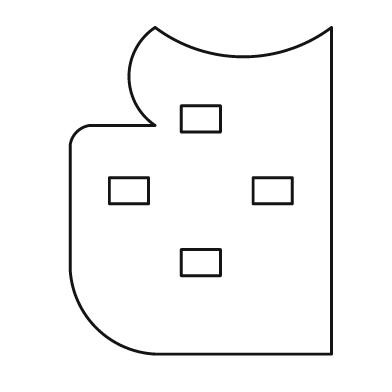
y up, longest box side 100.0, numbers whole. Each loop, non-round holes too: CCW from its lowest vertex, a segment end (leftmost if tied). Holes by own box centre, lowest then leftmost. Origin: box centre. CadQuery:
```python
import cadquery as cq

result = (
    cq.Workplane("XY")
    .moveTo(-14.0, -50.0)
    .lineTo(40.0, -50.0)
    .lineTo(40.0, 50.0)
    .threePointArc((13.0, 41.0), (-14.0, 50.0))
    .threePointArc((-22.0, 35.0), (-14.0, 20.0))
    .lineTo(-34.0, 20.0)
    .threePointArc((-38.0, 18.0), (-40.0, 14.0))
    .lineTo(-40.0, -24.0)
    .threePointArc((-32.0, -42.0), (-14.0, -50.0))
    .close()
    .moveTo(-6.0, -26.0)
    .lineTo(6.0, -26.0)
    .lineTo(6.0, -18.0)
    .lineTo(-6.0, -18.0)
    .close()
    .moveTo(-28.0, -4.0)
    .lineTo(-16.0, -4.0)
    .lineTo(-16.0, 4.0)
    .lineTo(-28.0, 4.0)
    .close()
    .moveTo(16.0, -4.0)
    .lineTo(28.0, -4.0)
    .lineTo(28.0, 4.0)
    .lineTo(16.0, 4.0)
    .close()
    .moveTo(-6.0, 18.0)
    .lineTo(6.0, 18.0)
    .lineTo(6.0, 26.0)
    .lineTo(-6.0, 26.0)
    .close()
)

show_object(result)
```